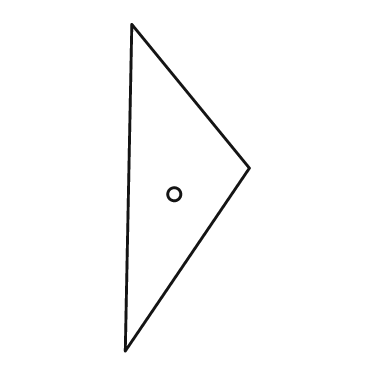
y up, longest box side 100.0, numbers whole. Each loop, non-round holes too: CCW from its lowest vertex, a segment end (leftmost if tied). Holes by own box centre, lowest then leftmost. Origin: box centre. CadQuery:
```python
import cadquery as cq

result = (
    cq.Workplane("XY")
    .moveTo(-19.0, -50.0)
    .lineTo(19.0, 6.0)
    .lineTo(-17.0, 50.0)
    .close()
    .moveTo(-4.0, -2.0)
    .circle(2.0)
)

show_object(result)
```